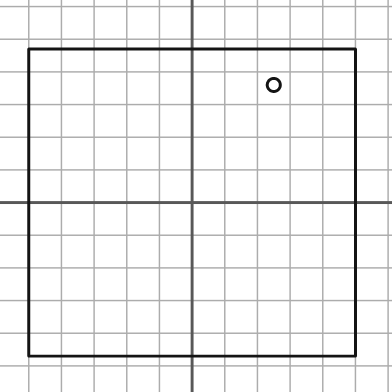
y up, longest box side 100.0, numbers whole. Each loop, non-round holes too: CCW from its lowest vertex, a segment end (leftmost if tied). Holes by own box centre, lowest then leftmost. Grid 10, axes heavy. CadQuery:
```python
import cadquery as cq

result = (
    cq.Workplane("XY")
    .moveTo(-50.0, -47.0)
    .lineTo(50.0, -47.0)
    .lineTo(50.0, 47.0)
    .lineTo(-50.0, 47.0)
    .close()
    .moveTo(25.0, 36.0)
    .circle(2.0)
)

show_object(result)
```